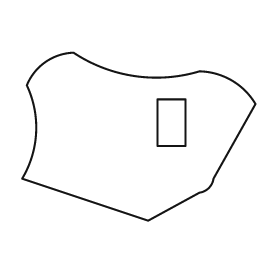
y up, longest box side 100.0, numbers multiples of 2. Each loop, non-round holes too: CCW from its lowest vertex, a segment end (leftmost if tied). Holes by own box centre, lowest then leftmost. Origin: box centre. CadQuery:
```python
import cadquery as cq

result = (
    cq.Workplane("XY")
    .moveTo(4.0, -36.0)
    .lineTo(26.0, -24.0)
    .threePointArc((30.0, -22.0), (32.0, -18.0))
    .lineTo(50.0, 14.0)
    .threePointArc((40.0, 24.0), (26.0, 28.0))
    .threePointArc((-2.0, 26.0), (-28.0, 36.0))
    .threePointArc((-40.0, 32.0), (-48.0, 22.0))
    .threePointArc((-44.0, 2.0), (-50.0, -18.0))
    .close()
    .moveTo(8.0, -4.0)
    .lineTo(20.0, -4.0)
    .lineTo(20.0, 16.0)
    .lineTo(8.0, 16.0)
    .close()
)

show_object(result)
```